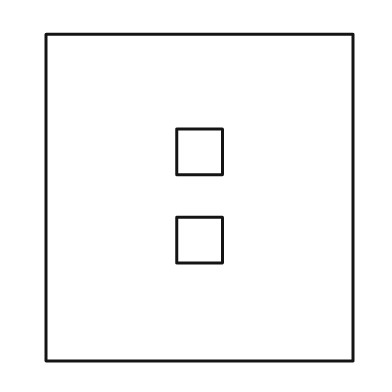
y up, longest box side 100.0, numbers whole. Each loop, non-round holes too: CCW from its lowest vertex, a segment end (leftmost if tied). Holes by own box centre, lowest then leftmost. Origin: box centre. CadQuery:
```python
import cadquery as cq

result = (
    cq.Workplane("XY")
    .moveTo(-47.0, -50.0)
    .lineTo(47.0, -50.0)
    .lineTo(47.0, 50.0)
    .lineTo(-47.0, 50.0)
    .close()
    .moveTo(-7.0, -20.0)
    .lineTo(7.0, -20.0)
    .lineTo(7.0, -6.0)
    .lineTo(-7.0, -6.0)
    .close()
    .moveTo(-7.0, 7.0)
    .lineTo(7.0, 7.0)
    .lineTo(7.0, 21.0)
    .lineTo(-7.0, 21.0)
    .close()
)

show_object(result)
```